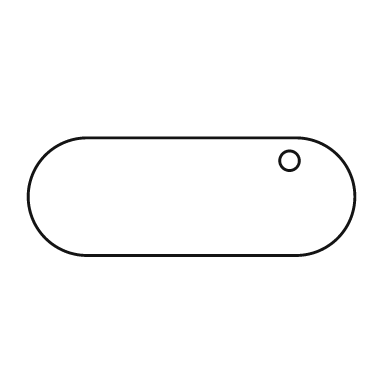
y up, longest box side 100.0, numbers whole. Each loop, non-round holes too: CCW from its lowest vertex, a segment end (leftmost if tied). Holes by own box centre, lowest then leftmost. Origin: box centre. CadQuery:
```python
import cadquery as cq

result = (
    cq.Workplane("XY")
    .moveTo(-32.0, -18.0)
    .lineTo(32.0, -18.0)
    .threePointArc((50.0, 0.0), (32.0, 18.0))
    .lineTo(-32.0, 18.0)
    .threePointArc((-50.0, 0.0), (-32.0, -18.0))
    .close()
    .moveTo(30.0, 11.0)
    .circle(3.0)
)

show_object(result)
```